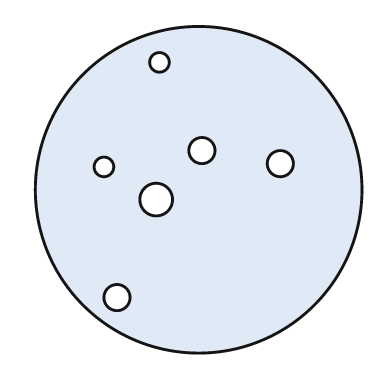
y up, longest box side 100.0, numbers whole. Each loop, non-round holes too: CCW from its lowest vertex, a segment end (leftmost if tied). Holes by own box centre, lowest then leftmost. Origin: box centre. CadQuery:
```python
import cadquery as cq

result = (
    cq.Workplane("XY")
    .moveTo(0.0, 0.0)
    .circle(50.0)
    .moveTo(-25.0, -33.0)
    .circle(4.0)
    .moveTo(-13.0, -3.0)
    .circle(5.0)
    .moveTo(-29.0, 7.0)
    .circle(3.0)
    .moveTo(25.0, 8.0)
    .circle(4.0)
    .moveTo(1.0, 12.0)
    .circle(4.0)
    .moveTo(-12.0, 39.0)
    .circle(3.0)
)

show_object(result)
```